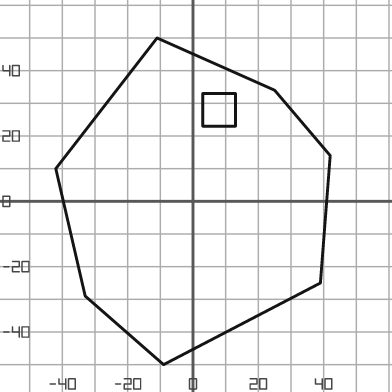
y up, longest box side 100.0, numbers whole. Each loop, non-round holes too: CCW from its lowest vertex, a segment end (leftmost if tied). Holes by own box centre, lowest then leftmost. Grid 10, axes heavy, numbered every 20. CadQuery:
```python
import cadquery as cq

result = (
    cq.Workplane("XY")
    .moveTo(-9.0, -50.0)
    .lineTo(39.0, -25.0)
    .lineTo(42.0, 14.0)
    .lineTo(25.0, 34.0)
    .lineTo(-11.0, 50.0)
    .lineTo(-42.0, 10.0)
    .lineTo(-33.0, -29.0)
    .close()
    .moveTo(3.0, 23.0)
    .lineTo(13.0, 23.0)
    .lineTo(13.0, 33.0)
    .lineTo(3.0, 33.0)
    .close()
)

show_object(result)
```